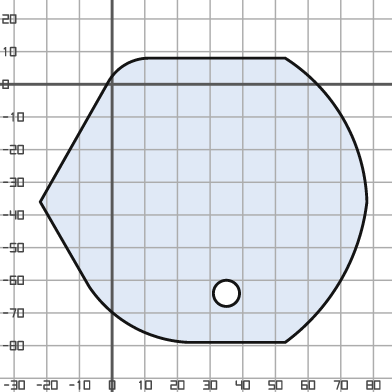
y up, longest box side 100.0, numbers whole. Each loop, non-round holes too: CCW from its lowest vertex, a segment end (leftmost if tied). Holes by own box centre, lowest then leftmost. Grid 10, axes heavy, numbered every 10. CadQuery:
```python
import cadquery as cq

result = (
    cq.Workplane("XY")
    .moveTo(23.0, -79.0)
    .lineTo(53.0, -79.0)
    .threePointArc((70.0, -60.0), (78.0, -36.0))
    .threePointArc((71.0, -11.0), (53.0, 8.0))
    .lineTo(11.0, 8.0)
    .threePointArc((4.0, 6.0), (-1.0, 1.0))
    .lineTo(-22.0, -36.0)
    .lineTo(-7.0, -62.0)
    .threePointArc((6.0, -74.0), (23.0, -79.0))
    .close()
    .moveTo(35.0, -64.0)
    .circle(4.0)
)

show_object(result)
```